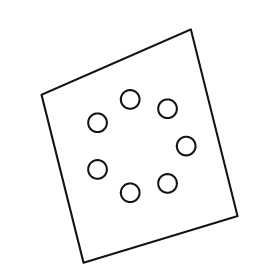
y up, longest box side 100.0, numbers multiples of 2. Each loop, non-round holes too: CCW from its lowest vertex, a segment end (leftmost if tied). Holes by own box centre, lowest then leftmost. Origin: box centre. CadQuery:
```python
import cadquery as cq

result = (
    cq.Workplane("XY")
    .moveTo(-24.0, -50.0)
    .lineTo(42.0, -30.0)
    .lineTo(22.0, 50.0)
    .lineTo(-42.0, 22.0)
    .close()
    .moveTo(-4.0, -20.0)
    .circle(4.0)
    .moveTo(12.0, -16.0)
    .circle(4.0)
    .moveTo(-18.0, -10.0)
    .circle(4.0)
    .moveTo(20.0, 0.0)
    .circle(4.0)
    .moveTo(-18.0, 10.0)
    .circle(4.0)
    .moveTo(12.0, 16.0)
    .circle(4.0)
    .moveTo(-4.0, 20.0)
    .circle(4.0)
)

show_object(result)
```